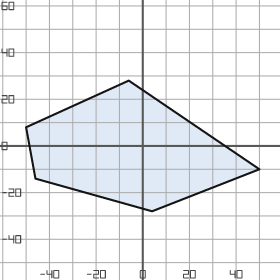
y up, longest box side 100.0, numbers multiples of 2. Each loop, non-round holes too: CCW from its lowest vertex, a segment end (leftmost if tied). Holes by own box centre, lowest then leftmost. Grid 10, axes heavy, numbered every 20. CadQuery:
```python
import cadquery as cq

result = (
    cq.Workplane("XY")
    .moveTo(4.0, -28.0)
    .lineTo(50.0, -10.0)
    .lineTo(-6.0, 28.0)
    .lineTo(-50.0, 8.0)
    .lineTo(-46.0, -14.0)
    .close()
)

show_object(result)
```